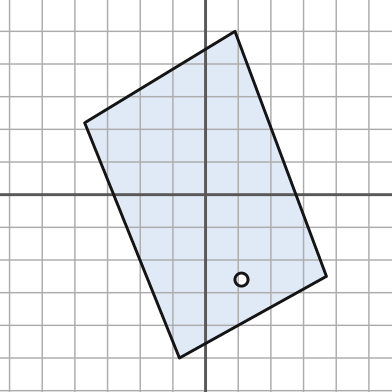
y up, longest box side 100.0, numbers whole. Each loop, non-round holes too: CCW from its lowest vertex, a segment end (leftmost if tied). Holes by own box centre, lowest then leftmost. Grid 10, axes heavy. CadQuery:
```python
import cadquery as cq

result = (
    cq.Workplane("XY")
    .moveTo(-8.0, -50.0)
    .lineTo(37.0, -25.0)
    .lineTo(9.0, 50.0)
    .lineTo(-37.0, 22.0)
    .close()
    .moveTo(11.0, -26.0)
    .circle(2.0)
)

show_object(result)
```